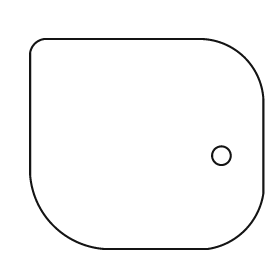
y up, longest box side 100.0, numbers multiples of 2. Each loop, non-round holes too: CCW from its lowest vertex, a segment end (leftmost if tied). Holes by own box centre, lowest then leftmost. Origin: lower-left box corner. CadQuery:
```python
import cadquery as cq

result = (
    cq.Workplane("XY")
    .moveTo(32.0, 0.0)
    .lineTo(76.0, 0.0)
    .threePointArc((92.0, 8.0), (100.0, 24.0))
    .lineTo(100.0, 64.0)
    .threePointArc((92.0, 82.0), (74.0, 90.0))
    .lineTo(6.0, 90.0)
    .threePointArc((2.0, 88.0), (0.0, 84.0))
    .lineTo(0.0, 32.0)
    .threePointArc((10.0, 10.0), (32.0, 0.0))
    .close()
    .moveTo(82.0, 40.0)
    .circle(4.0)
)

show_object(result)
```